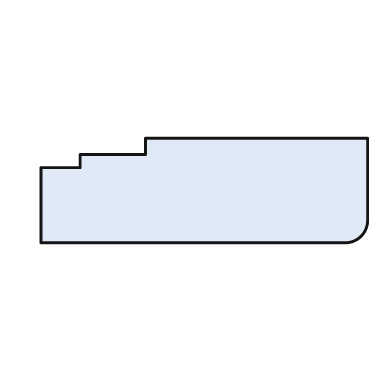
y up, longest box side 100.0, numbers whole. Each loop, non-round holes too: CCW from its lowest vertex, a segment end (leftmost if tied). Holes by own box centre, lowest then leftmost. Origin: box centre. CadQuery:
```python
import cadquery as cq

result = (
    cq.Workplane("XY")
    .moveTo(-50.0, -16.0)
    .lineTo(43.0, -16.0)
    .threePointArc((48.0, -14.0), (50.0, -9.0))
    .lineTo(50.0, 16.0)
    .lineTo(-18.0, 16.0)
    .lineTo(-18.0, 11.0)
    .lineTo(-38.0, 11.0)
    .lineTo(-38.0, 7.0)
    .lineTo(-50.0, 7.0)
    .close()
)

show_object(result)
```